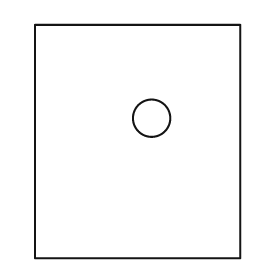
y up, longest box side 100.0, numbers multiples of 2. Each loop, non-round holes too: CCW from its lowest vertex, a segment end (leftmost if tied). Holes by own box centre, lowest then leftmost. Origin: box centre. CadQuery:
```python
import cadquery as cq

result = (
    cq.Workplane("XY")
    .moveTo(-44.0, -50.0)
    .lineTo(44.0, -50.0)
    .lineTo(44.0, 50.0)
    .lineTo(-44.0, 50.0)
    .close()
    .moveTo(6.0, 10.0)
    .circle(8.0)
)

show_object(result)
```